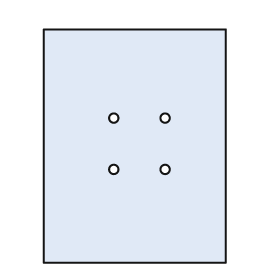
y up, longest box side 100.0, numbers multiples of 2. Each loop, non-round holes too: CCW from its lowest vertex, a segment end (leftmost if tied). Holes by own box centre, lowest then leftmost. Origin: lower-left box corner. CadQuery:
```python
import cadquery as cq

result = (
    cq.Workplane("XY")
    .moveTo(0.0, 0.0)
    .lineTo(78.0, 0.0)
    .lineTo(78.0, 100.0)
    .lineTo(0.0, 100.0)
    .close()
    .moveTo(30.0, 40.0)
    .circle(2.0)
    .moveTo(52.0, 40.0)
    .circle(2.0)
    .moveTo(30.0, 62.0)
    .circle(2.0)
    .moveTo(52.0, 62.0)
    .circle(2.0)
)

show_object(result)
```